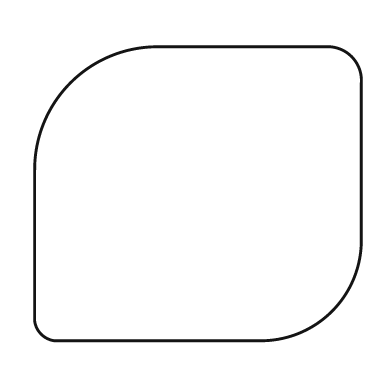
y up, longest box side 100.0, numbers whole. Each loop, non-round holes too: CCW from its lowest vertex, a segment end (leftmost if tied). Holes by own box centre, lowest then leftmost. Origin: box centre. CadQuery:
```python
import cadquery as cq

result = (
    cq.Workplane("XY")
    .moveTo(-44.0, -45.0)
    .lineTo(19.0, -45.0)
    .threePointArc((41.0, -36.0), (50.0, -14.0))
    .lineTo(50.0, 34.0)
    .threePointArc((47.0, 42.0), (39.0, 45.0))
    .lineTo(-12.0, 45.0)
    .threePointArc((-39.0, 34.0), (-50.0, 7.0))
    .lineTo(-50.0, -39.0)
    .threePointArc((-48.0, -43.0), (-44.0, -45.0))
    .close()
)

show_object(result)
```